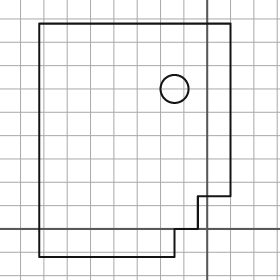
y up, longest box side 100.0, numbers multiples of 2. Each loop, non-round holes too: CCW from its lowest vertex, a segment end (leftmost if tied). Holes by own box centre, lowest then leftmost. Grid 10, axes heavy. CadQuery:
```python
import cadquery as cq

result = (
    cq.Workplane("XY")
    .moveTo(-72.0, -12.0)
    .lineTo(-14.0, -12.0)
    .lineTo(-14.0, 0.0)
    .lineTo(-4.0, 0.0)
    .lineTo(-4.0, 14.0)
    .lineTo(10.0, 14.0)
    .lineTo(10.0, 88.0)
    .lineTo(-72.0, 88.0)
    .close()
    .moveTo(-14.0, 60.0)
    .circle(6.0)
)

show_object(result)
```